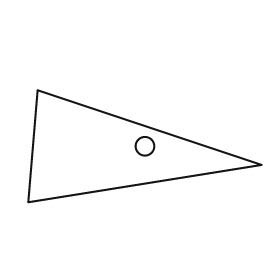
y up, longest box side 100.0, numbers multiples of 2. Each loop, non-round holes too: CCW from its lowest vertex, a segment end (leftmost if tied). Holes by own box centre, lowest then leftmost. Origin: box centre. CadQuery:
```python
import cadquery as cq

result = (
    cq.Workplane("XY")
    .moveTo(-50.0, -24.0)
    .lineTo(50.0, -8.0)
    .lineTo(-46.0, 24.0)
    .close()
    .moveTo(0.0, 0.0)
    .circle(4.0)
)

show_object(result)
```